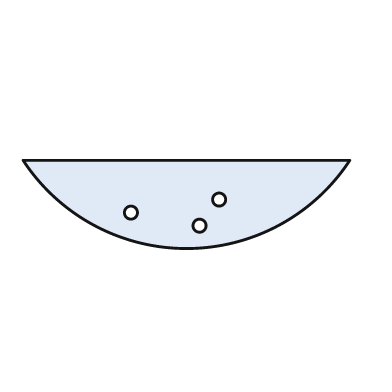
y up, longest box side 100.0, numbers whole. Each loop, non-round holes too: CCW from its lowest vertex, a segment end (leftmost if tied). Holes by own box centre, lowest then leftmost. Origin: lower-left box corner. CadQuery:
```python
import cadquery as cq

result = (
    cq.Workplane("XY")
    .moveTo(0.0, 27.0)
    .threePointArc((50.0, 0.0), (100.0, 27.0))
    .close()
    .moveTo(54.0, 7.0)
    .circle(2.0)
    .moveTo(33.0, 11.0)
    .circle(2.0)
    .moveTo(60.0, 15.0)
    .circle(2.0)
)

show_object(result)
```